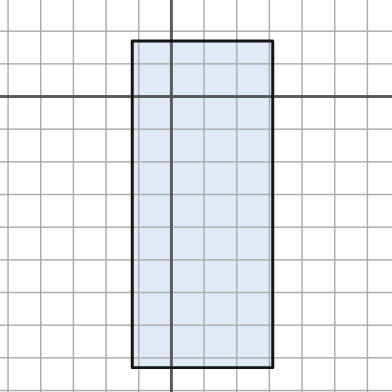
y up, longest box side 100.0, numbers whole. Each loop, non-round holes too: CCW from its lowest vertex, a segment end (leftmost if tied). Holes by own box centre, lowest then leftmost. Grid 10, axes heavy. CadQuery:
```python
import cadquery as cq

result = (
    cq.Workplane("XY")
    .moveTo(-12.0, -83.0)
    .lineTo(31.0, -83.0)
    .lineTo(31.0, 17.0)
    .lineTo(-12.0, 17.0)
    .close()
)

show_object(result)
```